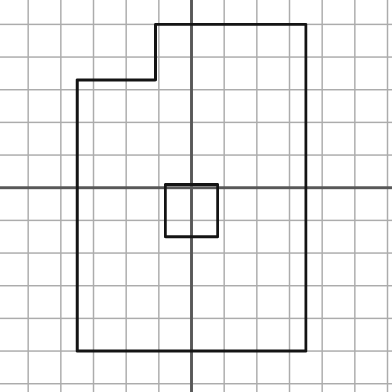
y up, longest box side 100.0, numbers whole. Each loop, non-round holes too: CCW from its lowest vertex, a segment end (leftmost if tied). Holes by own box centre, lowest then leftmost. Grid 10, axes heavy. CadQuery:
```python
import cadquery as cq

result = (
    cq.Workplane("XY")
    .moveTo(-35.0, -50.0)
    .lineTo(35.0, -50.0)
    .lineTo(35.0, 50.0)
    .lineTo(-11.0, 50.0)
    .lineTo(-11.0, 33.0)
    .lineTo(-35.0, 33.0)
    .close()
    .moveTo(-8.0, -15.0)
    .lineTo(8.0, -15.0)
    .lineTo(8.0, 1.0)
    .lineTo(-8.0, 1.0)
    .close()
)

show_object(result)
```